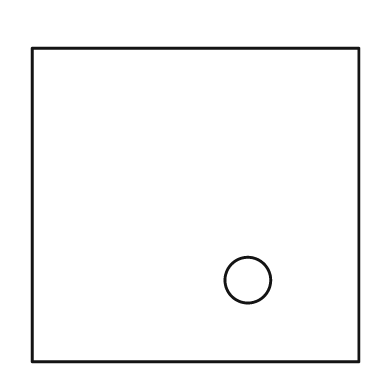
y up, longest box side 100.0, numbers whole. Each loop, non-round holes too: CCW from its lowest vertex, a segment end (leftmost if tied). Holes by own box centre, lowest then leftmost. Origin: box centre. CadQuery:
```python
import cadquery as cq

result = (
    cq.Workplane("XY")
    .moveTo(-50.0, -48.0)
    .lineTo(50.0, -48.0)
    .lineTo(50.0, 48.0)
    .lineTo(-50.0, 48.0)
    .close()
    .moveTo(16.0, -23.0)
    .circle(7.0)
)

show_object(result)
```